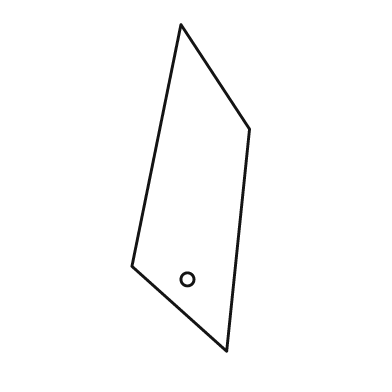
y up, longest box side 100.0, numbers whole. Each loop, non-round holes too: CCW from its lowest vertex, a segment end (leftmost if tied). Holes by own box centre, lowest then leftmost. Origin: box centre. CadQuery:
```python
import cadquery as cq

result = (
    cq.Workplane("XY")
    .moveTo(11.0, -50.0)
    .lineTo(18.0, 18.0)
    .lineTo(-3.0, 50.0)
    .lineTo(-18.0, -24.0)
    .close()
    .moveTo(-1.0, -28.0)
    .circle(2.0)
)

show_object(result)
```